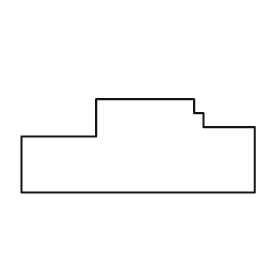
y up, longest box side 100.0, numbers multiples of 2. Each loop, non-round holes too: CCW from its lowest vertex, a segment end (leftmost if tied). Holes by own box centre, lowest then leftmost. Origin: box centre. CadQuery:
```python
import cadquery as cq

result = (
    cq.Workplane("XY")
    .moveTo(-50.0, -20.0)
    .lineTo(50.0, -20.0)
    .lineTo(50.0, 8.0)
    .lineTo(28.0, 8.0)
    .lineTo(28.0, 14.0)
    .lineTo(24.0, 14.0)
    .lineTo(24.0, 20.0)
    .lineTo(-18.0, 20.0)
    .lineTo(-18.0, 4.0)
    .lineTo(-50.0, 4.0)
    .close()
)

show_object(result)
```